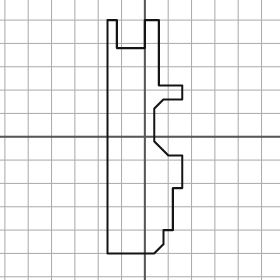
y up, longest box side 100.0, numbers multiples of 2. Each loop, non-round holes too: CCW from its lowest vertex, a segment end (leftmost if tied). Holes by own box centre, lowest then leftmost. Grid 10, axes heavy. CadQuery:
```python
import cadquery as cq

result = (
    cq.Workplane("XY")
    .moveTo(-16.0, -50.0)
    .lineTo(4.0, -50.0)
    .lineTo(8.0, -46.0)
    .lineTo(8.0, -40.0)
    .lineTo(12.0, -40.0)
    .lineTo(12.0, -22.0)
    .lineTo(16.0, -22.0)
    .lineTo(16.0, -8.0)
    .lineTo(10.0, -8.0)
    .lineTo(4.0, -2.0)
    .lineTo(4.0, 12.0)
    .lineTo(8.0, 16.0)
    .lineTo(16.0, 16.0)
    .lineTo(16.0, 22.0)
    .lineTo(6.0, 22.0)
    .lineTo(6.0, 50.0)
    .lineTo(0.0, 50.0)
    .lineTo(0.0, 38.0)
    .lineTo(-12.0, 38.0)
    .lineTo(-12.0, 50.0)
    .lineTo(-16.0, 50.0)
    .close()
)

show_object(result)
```